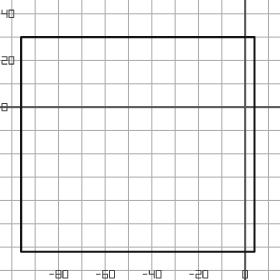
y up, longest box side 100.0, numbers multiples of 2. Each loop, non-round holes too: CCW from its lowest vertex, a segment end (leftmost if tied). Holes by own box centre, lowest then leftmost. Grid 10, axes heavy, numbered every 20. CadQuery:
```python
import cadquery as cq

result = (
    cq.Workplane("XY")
    .moveTo(-96.0, -62.0)
    .lineTo(4.0, -62.0)
    .lineTo(4.0, 30.0)
    .lineTo(-96.0, 30.0)
    .close()
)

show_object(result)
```